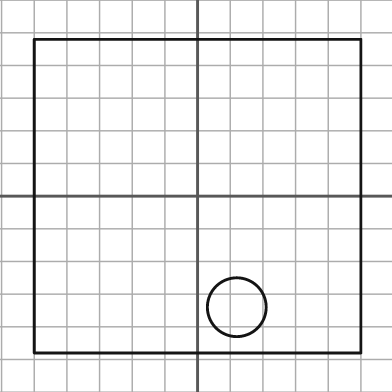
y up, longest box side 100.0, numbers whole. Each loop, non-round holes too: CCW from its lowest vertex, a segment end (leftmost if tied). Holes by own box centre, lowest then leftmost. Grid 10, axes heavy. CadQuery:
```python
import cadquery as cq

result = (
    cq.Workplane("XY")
    .moveTo(-50.0, -48.0)
    .lineTo(50.0, -48.0)
    .lineTo(50.0, 48.0)
    .lineTo(-50.0, 48.0)
    .close()
    .moveTo(12.0, -34.0)
    .circle(9.0)
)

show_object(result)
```